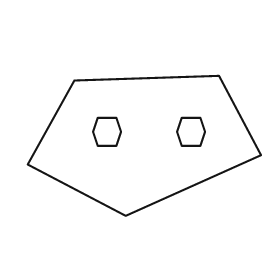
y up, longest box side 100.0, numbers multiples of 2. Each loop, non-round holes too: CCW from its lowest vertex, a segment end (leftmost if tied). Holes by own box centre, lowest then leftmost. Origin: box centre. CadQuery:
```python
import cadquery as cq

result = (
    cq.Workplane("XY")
    .moveTo(-8.0, -30.0)
    .lineTo(50.0, -4.0)
    .lineTo(32.0, 30.0)
    .lineTo(-30.0, 28.0)
    .lineTo(-50.0, -8.0)
    .close()
    .moveTo(-20.0, 0.0)
    .lineTo(-12.0, 0.0)
    .lineTo(-10.0, 6.0)
    .lineTo(-12.0, 12.0)
    .lineTo(-20.0, 12.0)
    .lineTo(-22.0, 6.0)
    .close()
    .moveTo(16.0, 0.0)
    .lineTo(24.0, 0.0)
    .lineTo(26.0, 6.0)
    .lineTo(24.0, 12.0)
    .lineTo(16.0, 12.0)
    .lineTo(14.0, 6.0)
    .close()
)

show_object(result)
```